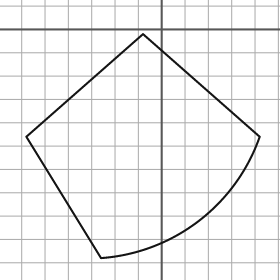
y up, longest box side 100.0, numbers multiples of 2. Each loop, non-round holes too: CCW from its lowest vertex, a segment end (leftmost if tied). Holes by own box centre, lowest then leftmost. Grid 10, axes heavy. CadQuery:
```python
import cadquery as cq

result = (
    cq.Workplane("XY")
    .moveTo(-26.0, -98.0)
    .threePointArc((16.0, -82.0), (42.0, -46.0))
    .lineTo(-8.0, -2.0)
    .lineTo(-58.0, -46.0)
    .close()
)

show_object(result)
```